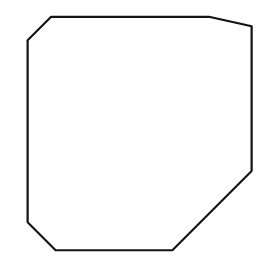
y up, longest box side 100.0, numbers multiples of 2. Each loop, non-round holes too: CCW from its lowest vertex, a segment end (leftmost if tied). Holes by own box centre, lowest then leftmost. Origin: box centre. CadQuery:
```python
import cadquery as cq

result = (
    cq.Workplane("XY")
    .moveTo(-36.0, -50.0)
    .lineTo(14.0, -50.0)
    .lineTo(48.0, -16.0)
    .lineTo(48.0, 46.0)
    .lineTo(30.0, 50.0)
    .lineTo(-38.0, 50.0)
    .lineTo(-48.0, 40.0)
    .lineTo(-48.0, -38.0)
    .close()
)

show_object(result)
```